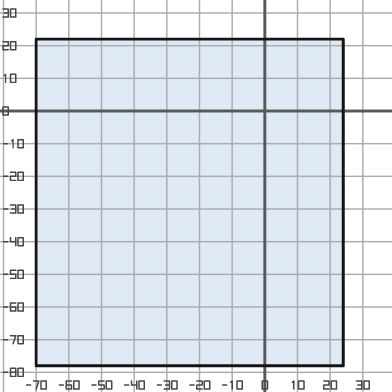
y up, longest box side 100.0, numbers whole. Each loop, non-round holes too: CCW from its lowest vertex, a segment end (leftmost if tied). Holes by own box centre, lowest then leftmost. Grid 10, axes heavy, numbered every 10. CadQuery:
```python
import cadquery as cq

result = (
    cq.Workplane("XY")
    .moveTo(-70.0, -78.0)
    .lineTo(24.0, -78.0)
    .lineTo(24.0, 22.0)
    .lineTo(-70.0, 22.0)
    .close()
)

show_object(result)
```